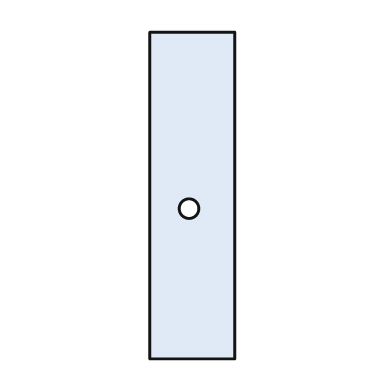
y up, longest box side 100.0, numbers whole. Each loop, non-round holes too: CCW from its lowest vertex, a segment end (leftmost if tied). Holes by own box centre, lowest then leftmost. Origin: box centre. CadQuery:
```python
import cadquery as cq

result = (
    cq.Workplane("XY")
    .moveTo(-13.0, -50.0)
    .lineTo(13.0, -50.0)
    .lineTo(13.0, 50.0)
    .lineTo(-13.0, 50.0)
    .close()
    .moveTo(-1.0, -4.0)
    .circle(3.0)
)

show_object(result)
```